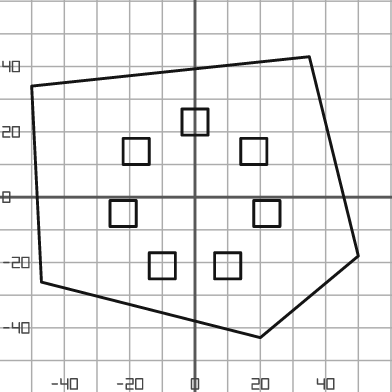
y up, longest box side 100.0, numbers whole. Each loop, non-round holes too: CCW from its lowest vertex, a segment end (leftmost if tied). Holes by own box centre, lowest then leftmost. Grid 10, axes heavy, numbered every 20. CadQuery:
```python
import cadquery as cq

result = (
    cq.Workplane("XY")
    .moveTo(20.0, -43.0)
    .lineTo(50.0, -18.0)
    .lineTo(35.0, 43.0)
    .lineTo(-50.0, 34.0)
    .lineTo(-47.0, -26.0)
    .close()
    .moveTo(-14.0, -25.0)
    .lineTo(-6.0, -25.0)
    .lineTo(-6.0, -17.0)
    .lineTo(-14.0, -17.0)
    .close()
    .moveTo(6.0, -25.0)
    .lineTo(14.0, -25.0)
    .lineTo(14.0, -17.0)
    .lineTo(6.0, -17.0)
    .close()
    .moveTo(-26.0, -9.0)
    .lineTo(-18.0, -9.0)
    .lineTo(-18.0, -1.0)
    .lineTo(-26.0, -1.0)
    .close()
    .moveTo(18.0, -9.0)
    .lineTo(26.0, -9.0)
    .lineTo(26.0, -1.0)
    .lineTo(18.0, -1.0)
    .close()
    .moveTo(-22.0, 10.0)
    .lineTo(-14.0, 10.0)
    .lineTo(-14.0, 18.0)
    .lineTo(-22.0, 18.0)
    .close()
    .moveTo(14.0, 10.0)
    .lineTo(22.0, 10.0)
    .lineTo(22.0, 18.0)
    .lineTo(14.0, 18.0)
    .close()
    .moveTo(-4.0, 19.0)
    .lineTo(4.0, 19.0)
    .lineTo(4.0, 27.0)
    .lineTo(-4.0, 27.0)
    .close()
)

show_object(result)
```